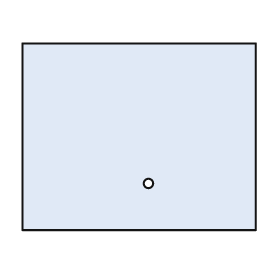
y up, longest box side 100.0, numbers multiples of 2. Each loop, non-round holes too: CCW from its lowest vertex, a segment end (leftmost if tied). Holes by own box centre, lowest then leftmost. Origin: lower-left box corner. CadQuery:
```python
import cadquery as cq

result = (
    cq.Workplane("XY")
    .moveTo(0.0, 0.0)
    .lineTo(100.0, 0.0)
    .lineTo(100.0, 80.0)
    .lineTo(0.0, 80.0)
    .close()
    .moveTo(54.0, 20.0)
    .circle(2.0)
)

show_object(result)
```